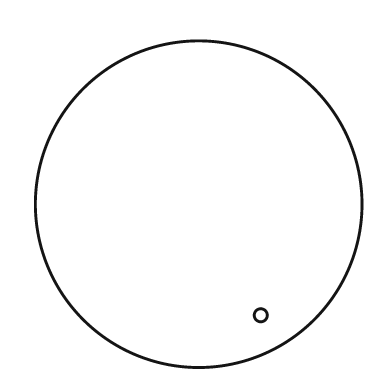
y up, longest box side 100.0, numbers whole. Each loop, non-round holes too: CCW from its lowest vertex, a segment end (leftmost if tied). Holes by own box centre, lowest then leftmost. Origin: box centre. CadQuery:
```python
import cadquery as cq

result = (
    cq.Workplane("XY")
    .moveTo(0.0, 0.0)
    .circle(50.0)
    .moveTo(19.0, -34.0)
    .circle(2.0)
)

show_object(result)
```